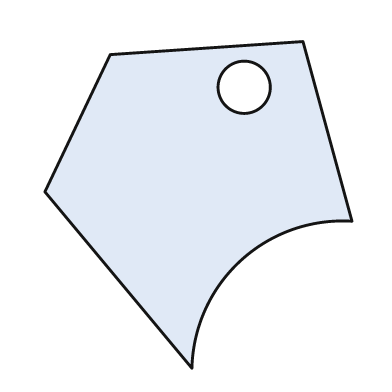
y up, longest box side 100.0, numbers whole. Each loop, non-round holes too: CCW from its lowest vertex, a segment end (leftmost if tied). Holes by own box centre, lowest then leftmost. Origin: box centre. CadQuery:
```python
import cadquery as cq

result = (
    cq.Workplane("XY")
    .moveTo(-2.0, -50.0)
    .threePointArc((13.0, -17.0), (47.0, -5.0))
    .lineTo(32.0, 50.0)
    .lineTo(-27.0, 46.0)
    .lineTo(-47.0, 4.0)
    .close()
    .moveTo(14.0, 36.0)
    .circle(8.0)
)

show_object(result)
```